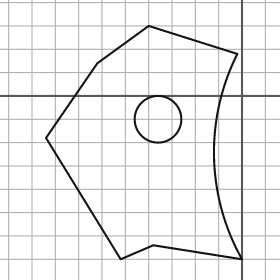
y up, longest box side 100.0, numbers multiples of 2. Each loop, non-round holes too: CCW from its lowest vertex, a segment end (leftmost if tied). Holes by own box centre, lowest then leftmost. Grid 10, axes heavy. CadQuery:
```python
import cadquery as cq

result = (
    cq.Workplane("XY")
    .moveTo(-52.0, -70.0)
    .lineTo(-38.0, -64.0)
    .lineTo(0.0, -70.0)
    .threePointArc((-12.0, -26.0), (-2.0, 18.0))
    .lineTo(-40.0, 30.0)
    .lineTo(-62.0, 14.0)
    .lineTo(-84.0, -18.0)
    .close()
    .moveTo(-36.0, -10.0)
    .circle(10.0)
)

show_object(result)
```